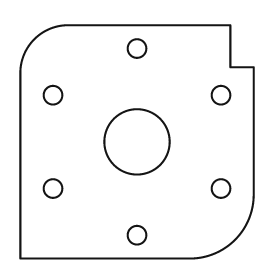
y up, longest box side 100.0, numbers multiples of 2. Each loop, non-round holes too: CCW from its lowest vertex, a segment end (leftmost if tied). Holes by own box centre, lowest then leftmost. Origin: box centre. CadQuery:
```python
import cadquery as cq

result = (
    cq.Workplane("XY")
    .moveTo(-50.0, -50.0)
    .lineTo(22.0, -50.0)
    .threePointArc((42.0, -42.0), (50.0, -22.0))
    .lineTo(50.0, 32.0)
    .lineTo(40.0, 32.0)
    .lineTo(40.0, 50.0)
    .lineTo(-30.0, 50.0)
    .threePointArc((-44.0, 44.0), (-50.0, 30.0))
    .close()
    .moveTo(0.0, -40.0)
    .circle(4.0)
    .moveTo(-36.0, -20.0)
    .circle(4.0)
    .moveTo(36.0, -20.0)
    .circle(4.0)
    .moveTo(0.0, 0.0)
    .circle(14.0)
    .moveTo(-36.0, 20.0)
    .circle(4.0)
    .moveTo(36.0, 20.0)
    .circle(4.0)
    .moveTo(0.0, 40.0)
    .circle(4.0)
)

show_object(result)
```